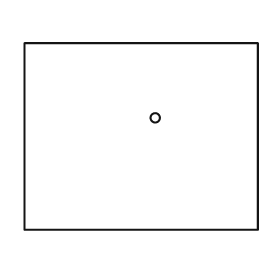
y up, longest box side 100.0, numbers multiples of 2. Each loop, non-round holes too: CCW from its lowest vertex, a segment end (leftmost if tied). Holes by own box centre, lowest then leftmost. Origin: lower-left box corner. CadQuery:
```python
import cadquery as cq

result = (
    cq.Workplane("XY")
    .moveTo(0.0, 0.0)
    .lineTo(100.0, 0.0)
    .lineTo(100.0, 80.0)
    .lineTo(0.0, 80.0)
    .close()
    .moveTo(56.0, 48.0)
    .circle(2.0)
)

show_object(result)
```